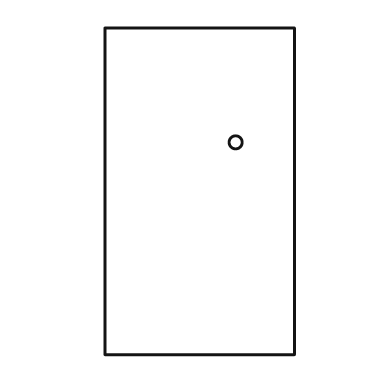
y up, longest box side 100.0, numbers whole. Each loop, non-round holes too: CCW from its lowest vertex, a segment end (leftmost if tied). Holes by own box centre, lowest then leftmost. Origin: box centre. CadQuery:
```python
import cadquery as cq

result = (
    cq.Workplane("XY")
    .moveTo(-29.0, -50.0)
    .lineTo(29.0, -50.0)
    .lineTo(29.0, 50.0)
    .lineTo(-29.0, 50.0)
    .close()
    .moveTo(11.0, 15.0)
    .circle(2.0)
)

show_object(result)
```